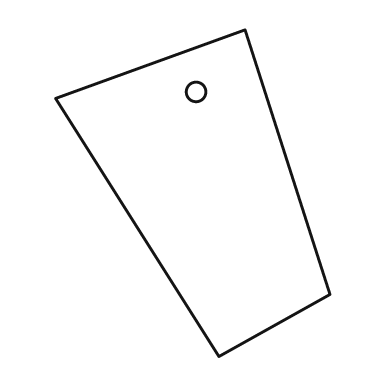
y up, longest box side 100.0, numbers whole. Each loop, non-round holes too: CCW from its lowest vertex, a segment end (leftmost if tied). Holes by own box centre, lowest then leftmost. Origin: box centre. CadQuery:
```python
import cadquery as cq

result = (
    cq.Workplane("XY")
    .moveTo(8.0, -50.0)
    .lineTo(42.0, -31.0)
    .lineTo(16.0, 50.0)
    .lineTo(-42.0, 29.0)
    .close()
    .moveTo(1.0, 31.0)
    .circle(3.0)
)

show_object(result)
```